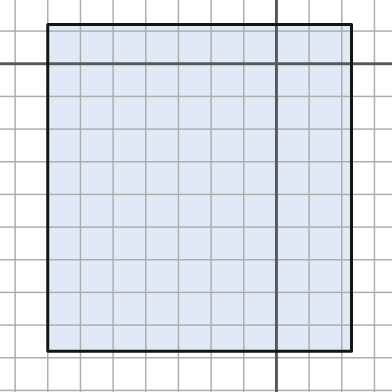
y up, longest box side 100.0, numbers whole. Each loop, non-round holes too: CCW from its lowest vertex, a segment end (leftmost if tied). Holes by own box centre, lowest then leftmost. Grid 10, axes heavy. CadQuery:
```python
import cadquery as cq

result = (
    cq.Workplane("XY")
    .moveTo(-70.0, -88.0)
    .lineTo(23.0, -88.0)
    .lineTo(23.0, 12.0)
    .lineTo(-70.0, 12.0)
    .close()
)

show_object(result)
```